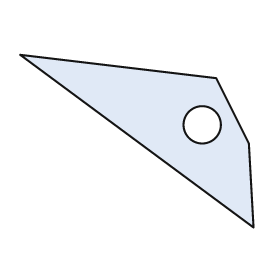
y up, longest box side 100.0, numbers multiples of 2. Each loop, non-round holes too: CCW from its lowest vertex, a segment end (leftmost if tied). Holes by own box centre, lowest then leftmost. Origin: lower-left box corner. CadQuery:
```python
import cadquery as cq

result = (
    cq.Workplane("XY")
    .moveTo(100.0, 0.0)
    .lineTo(98.0, 36.0)
    .lineTo(84.0, 64.0)
    .lineTo(0.0, 74.0)
    .close()
    .moveTo(78.0, 44.0)
    .circle(8.0)
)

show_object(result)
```